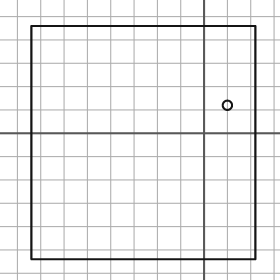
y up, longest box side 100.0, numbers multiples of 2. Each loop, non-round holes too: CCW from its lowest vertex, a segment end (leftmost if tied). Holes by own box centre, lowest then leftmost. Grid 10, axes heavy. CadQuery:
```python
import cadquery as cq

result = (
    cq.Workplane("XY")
    .moveTo(-74.0, -54.0)
    .lineTo(22.0, -54.0)
    .lineTo(22.0, 46.0)
    .lineTo(-74.0, 46.0)
    .close()
    .moveTo(10.0, 12.0)
    .circle(2.0)
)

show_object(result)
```